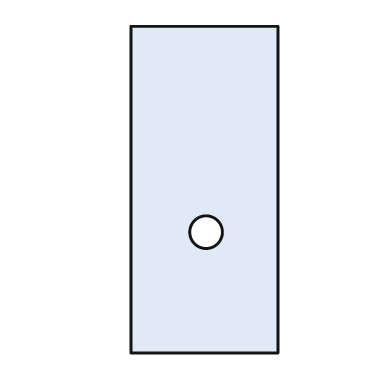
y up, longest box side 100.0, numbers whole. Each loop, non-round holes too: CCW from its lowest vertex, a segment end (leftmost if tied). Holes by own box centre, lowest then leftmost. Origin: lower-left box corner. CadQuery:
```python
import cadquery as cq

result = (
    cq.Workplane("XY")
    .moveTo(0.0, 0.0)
    .lineTo(45.0, 0.0)
    .lineTo(45.0, 100.0)
    .lineTo(0.0, 100.0)
    .close()
    .moveTo(23.0, 37.0)
    .circle(5.0)
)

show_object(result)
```